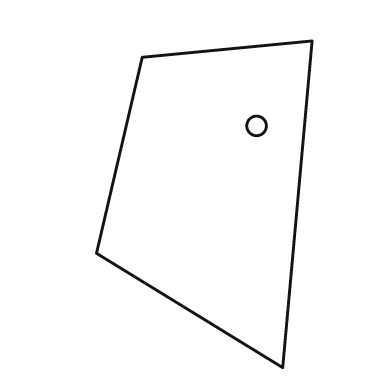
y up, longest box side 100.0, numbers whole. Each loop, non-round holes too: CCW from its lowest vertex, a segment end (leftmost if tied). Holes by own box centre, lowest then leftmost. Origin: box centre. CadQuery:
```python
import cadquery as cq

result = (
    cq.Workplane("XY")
    .moveTo(24.0, -50.0)
    .lineTo(33.0, 50.0)
    .lineTo(-19.0, 45.0)
    .lineTo(-33.0, -15.0)
    .close()
    .moveTo(16.0, 24.0)
    .circle(3.0)
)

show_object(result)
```